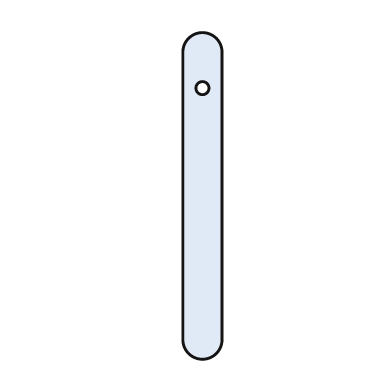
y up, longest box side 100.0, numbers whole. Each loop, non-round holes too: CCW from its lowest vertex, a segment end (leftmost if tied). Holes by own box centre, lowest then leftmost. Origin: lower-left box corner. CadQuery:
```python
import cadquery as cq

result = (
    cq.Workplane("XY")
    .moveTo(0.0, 6.0)
    .threePointArc((6.0, 0.0), (12.0, 6.0))
    .lineTo(12.0, 94.0)
    .threePointArc((6.0, 100.0), (0.0, 94.0))
    .close()
    .moveTo(6.0, 83.0)
    .circle(2.0)
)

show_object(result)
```